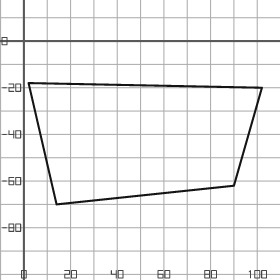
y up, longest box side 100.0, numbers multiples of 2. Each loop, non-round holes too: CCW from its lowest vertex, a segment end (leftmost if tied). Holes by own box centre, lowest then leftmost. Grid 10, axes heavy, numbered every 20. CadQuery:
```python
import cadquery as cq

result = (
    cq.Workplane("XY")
    .moveTo(14.0, -70.0)
    .lineTo(90.0, -62.0)
    .lineTo(102.0, -20.0)
    .lineTo(2.0, -18.0)
    .close()
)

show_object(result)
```